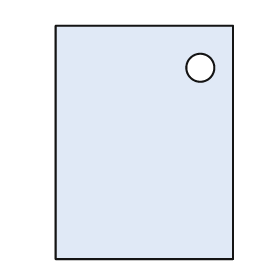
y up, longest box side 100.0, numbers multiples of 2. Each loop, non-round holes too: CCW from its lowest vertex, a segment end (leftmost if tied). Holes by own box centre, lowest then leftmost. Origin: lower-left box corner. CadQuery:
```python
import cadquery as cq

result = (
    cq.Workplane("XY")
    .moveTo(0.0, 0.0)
    .lineTo(76.0, 0.0)
    .lineTo(76.0, 100.0)
    .lineTo(0.0, 100.0)
    .close()
    .moveTo(62.0, 82.0)
    .circle(6.0)
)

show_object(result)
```